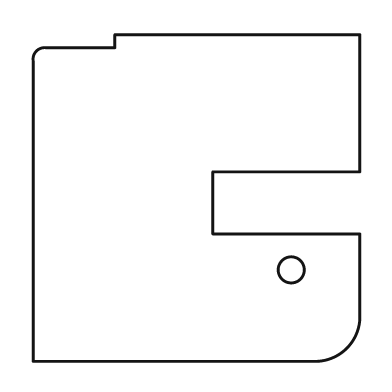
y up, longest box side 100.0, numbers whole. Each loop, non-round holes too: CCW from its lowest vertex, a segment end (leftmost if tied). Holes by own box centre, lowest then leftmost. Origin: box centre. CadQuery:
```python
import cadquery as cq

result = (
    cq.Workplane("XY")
    .moveTo(-50.0, -50.0)
    .lineTo(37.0, -50.0)
    .threePointArc((46.0, -46.0), (50.0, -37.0))
    .lineTo(50.0, -11.0)
    .lineTo(5.0, -11.0)
    .lineTo(5.0, 8.0)
    .lineTo(50.0, 8.0)
    .lineTo(50.0, 50.0)
    .lineTo(-25.0, 50.0)
    .lineTo(-25.0, 46.0)
    .lineTo(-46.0, 46.0)
    .threePointArc((-49.0, 45.0), (-50.0, 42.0))
    .close()
    .moveTo(29.0, -22.0)
    .circle(4.0)
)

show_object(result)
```